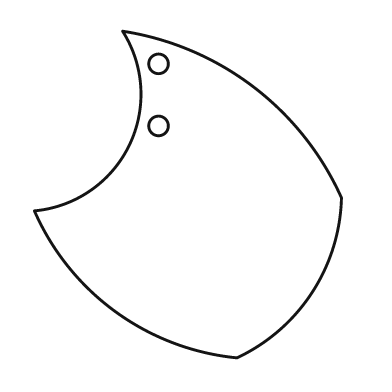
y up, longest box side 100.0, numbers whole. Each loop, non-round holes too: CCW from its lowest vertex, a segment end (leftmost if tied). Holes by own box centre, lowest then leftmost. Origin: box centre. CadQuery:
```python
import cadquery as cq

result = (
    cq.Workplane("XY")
    .moveTo(15.0, -50.0)
    .threePointArc((38.0, -30.0), (47.0, -1.0))
    .threePointArc((20.0, 33.0), (-20.0, 50.0))
    .threePointArc((-18.0, 15.0), (-47.0, -5.0))
    .threePointArc((-22.0, -36.0), (15.0, -50.0))
    .close()
    .moveTo(-9.0, 21.0)
    .circle(3.0)
    .moveTo(-9.0, 40.0)
    .circle(3.0)
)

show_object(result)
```